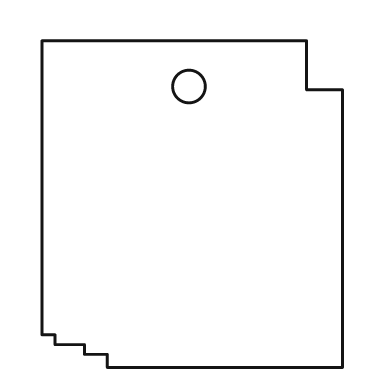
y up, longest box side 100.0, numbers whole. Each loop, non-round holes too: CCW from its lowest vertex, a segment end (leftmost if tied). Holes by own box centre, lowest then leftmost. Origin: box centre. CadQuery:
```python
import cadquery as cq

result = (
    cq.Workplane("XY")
    .moveTo(-26.0, -50.0)
    .lineTo(46.0, -50.0)
    .lineTo(46.0, 35.0)
    .lineTo(35.0, 35.0)
    .lineTo(35.0, 50.0)
    .lineTo(-46.0, 50.0)
    .lineTo(-46.0, -40.0)
    .lineTo(-42.0, -40.0)
    .lineTo(-42.0, -43.0)
    .lineTo(-33.0, -43.0)
    .lineTo(-33.0, -46.0)
    .lineTo(-26.0, -46.0)
    .close()
    .moveTo(-1.0, 36.0)
    .circle(5.0)
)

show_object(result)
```